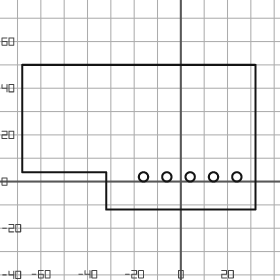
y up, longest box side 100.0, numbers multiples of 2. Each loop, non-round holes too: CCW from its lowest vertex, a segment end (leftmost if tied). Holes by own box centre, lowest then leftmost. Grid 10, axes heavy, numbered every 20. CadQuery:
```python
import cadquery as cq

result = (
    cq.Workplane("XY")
    .moveTo(-32.0, -12.0)
    .lineTo(32.0, -12.0)
    .lineTo(32.0, 50.0)
    .lineTo(-68.0, 50.0)
    .lineTo(-68.0, 4.0)
    .lineTo(-32.0, 4.0)
    .close()
    .moveTo(-16.0, 2.0)
    .circle(2.0)
    .moveTo(-6.0, 2.0)
    .circle(2.0)
    .moveTo(4.0, 2.0)
    .circle(2.0)
    .moveTo(14.0, 2.0)
    .circle(2.0)
    .moveTo(24.0, 2.0)
    .circle(2.0)
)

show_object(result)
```